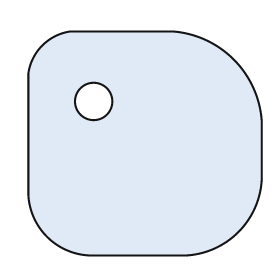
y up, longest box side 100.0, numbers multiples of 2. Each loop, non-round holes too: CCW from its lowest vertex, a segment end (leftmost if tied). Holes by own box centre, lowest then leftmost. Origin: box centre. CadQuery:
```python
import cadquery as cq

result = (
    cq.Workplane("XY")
    .moveTo(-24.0, -48.0)
    .lineTo(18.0, -48.0)
    .threePointArc((40.0, -38.0), (50.0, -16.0))
    .lineTo(50.0, 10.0)
    .threePointArc((38.0, 36.0), (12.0, 48.0))
    .lineTo(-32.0, 48.0)
    .threePointArc((-44.0, 42.0), (-50.0, 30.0))
    .lineTo(-50.0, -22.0)
    .threePointArc((-42.0, -40.0), (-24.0, -48.0))
    .close()
    .moveTo(-22.0, 18.0)
    .circle(8.0)
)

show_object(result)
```